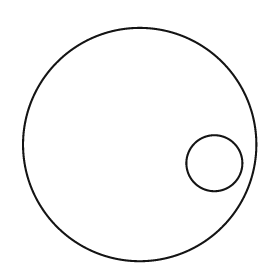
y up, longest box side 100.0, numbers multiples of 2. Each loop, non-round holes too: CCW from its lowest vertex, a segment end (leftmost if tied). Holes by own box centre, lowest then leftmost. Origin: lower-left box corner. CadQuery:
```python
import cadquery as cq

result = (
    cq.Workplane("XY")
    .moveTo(50.0, 50.0)
    .circle(50.0)
    .moveTo(82.0, 42.0)
    .circle(12.0)
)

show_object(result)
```